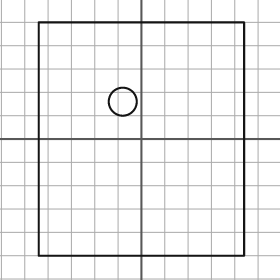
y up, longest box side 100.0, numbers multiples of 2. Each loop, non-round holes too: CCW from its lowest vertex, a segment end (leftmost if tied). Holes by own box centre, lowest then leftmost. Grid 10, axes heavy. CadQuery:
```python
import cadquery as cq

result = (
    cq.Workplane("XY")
    .moveTo(-44.0, -50.0)
    .lineTo(44.0, -50.0)
    .lineTo(44.0, 50.0)
    .lineTo(-44.0, 50.0)
    .close()
    .moveTo(-8.0, 16.0)
    .circle(6.0)
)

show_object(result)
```